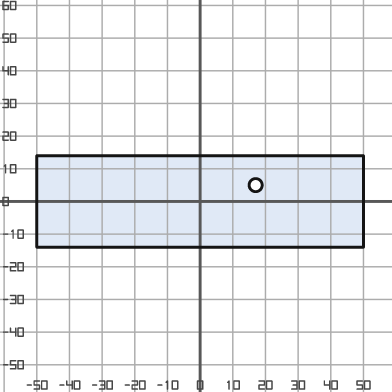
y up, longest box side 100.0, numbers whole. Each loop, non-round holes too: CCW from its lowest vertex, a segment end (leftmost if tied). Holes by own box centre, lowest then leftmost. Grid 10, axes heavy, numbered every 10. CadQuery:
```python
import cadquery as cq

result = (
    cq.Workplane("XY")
    .moveTo(-50.0, -14.0)
    .lineTo(50.0, -14.0)
    .lineTo(50.0, 14.0)
    .lineTo(-50.0, 14.0)
    .close()
    .moveTo(17.0, 5.0)
    .circle(2.0)
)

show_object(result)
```